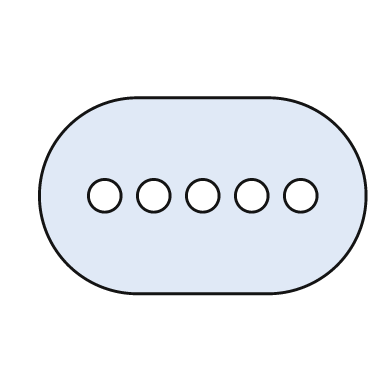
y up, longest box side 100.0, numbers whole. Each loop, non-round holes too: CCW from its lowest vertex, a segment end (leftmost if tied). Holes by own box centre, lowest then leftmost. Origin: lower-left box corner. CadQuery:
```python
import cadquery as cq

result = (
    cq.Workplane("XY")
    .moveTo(30.0, 0.0)
    .lineTo(70.0, 0.0)
    .threePointArc((100.0, 30.0), (70.0, 60.0))
    .lineTo(30.0, 60.0)
    .threePointArc((0.0, 30.0), (30.0, 0.0))
    .close()
    .moveTo(20.0, 30.0)
    .circle(5.0)
    .moveTo(35.0, 30.0)
    .circle(5.0)
    .moveTo(50.0, 30.0)
    .circle(5.0)
    .moveTo(65.0, 30.0)
    .circle(5.0)
    .moveTo(80.0, 30.0)
    .circle(5.0)
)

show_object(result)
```